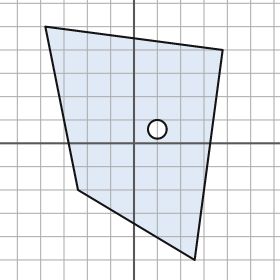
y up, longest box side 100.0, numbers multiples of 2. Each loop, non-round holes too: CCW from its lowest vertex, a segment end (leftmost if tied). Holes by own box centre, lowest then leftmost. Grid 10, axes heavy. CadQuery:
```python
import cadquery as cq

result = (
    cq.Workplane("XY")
    .moveTo(26.0, -50.0)
    .lineTo(38.0, 40.0)
    .lineTo(-38.0, 50.0)
    .lineTo(-24.0, -20.0)
    .close()
    .moveTo(10.0, 6.0)
    .circle(4.0)
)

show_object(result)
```